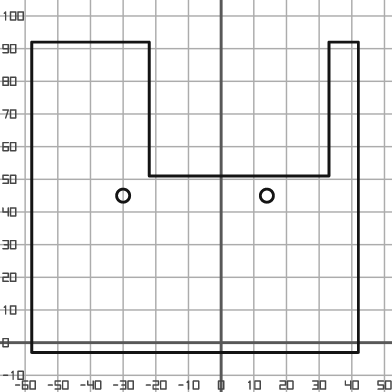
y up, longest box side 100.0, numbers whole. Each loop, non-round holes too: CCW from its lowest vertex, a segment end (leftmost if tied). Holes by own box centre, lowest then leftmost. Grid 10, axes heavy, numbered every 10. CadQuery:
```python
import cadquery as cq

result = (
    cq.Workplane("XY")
    .moveTo(-58.0, -3.0)
    .lineTo(42.0, -3.0)
    .lineTo(42.0, 92.0)
    .lineTo(33.0, 92.0)
    .lineTo(33.0, 51.0)
    .lineTo(-22.0, 51.0)
    .lineTo(-22.0, 92.0)
    .lineTo(-58.0, 92.0)
    .close()
    .moveTo(-30.0, 45.0)
    .circle(2.0)
    .moveTo(14.0, 45.0)
    .circle(2.0)
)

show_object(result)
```